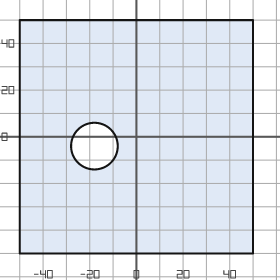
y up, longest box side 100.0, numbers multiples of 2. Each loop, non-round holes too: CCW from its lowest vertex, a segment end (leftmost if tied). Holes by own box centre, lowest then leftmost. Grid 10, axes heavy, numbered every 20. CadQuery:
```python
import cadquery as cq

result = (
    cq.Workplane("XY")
    .moveTo(-50.0, -50.0)
    .lineTo(50.0, -50.0)
    .lineTo(50.0, 50.0)
    .lineTo(-50.0, 50.0)
    .close()
    .moveTo(-18.0, -4.0)
    .circle(10.0)
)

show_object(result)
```